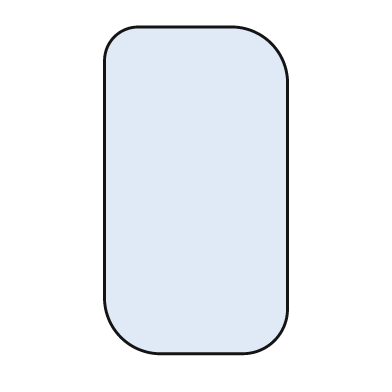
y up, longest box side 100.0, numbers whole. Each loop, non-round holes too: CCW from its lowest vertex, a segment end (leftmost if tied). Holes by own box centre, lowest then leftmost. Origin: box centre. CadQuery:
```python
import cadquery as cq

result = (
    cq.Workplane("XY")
    .moveTo(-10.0, -50.0)
    .lineTo(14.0, -50.0)
    .threePointArc((24.0, -46.0), (28.0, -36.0))
    .lineTo(28.0, 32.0)
    .threePointArc((23.0, 45.0), (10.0, 50.0))
    .lineTo(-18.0, 50.0)
    .threePointArc((-25.0, 47.0), (-28.0, 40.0))
    .lineTo(-28.0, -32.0)
    .threePointArc((-23.0, -45.0), (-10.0, -50.0))
    .close()
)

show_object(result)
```